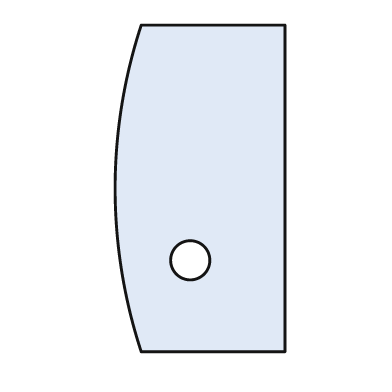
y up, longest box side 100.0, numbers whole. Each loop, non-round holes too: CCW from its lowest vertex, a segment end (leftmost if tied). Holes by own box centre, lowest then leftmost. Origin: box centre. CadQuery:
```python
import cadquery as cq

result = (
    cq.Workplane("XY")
    .moveTo(-18.0, -50.0)
    .lineTo(26.0, -50.0)
    .lineTo(26.0, 50.0)
    .lineTo(-18.0, 50.0)
    .threePointArc((-26.0, 0.0), (-18.0, -50.0))
    .close()
    .moveTo(-3.0, -22.0)
    .circle(6.0)
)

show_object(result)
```